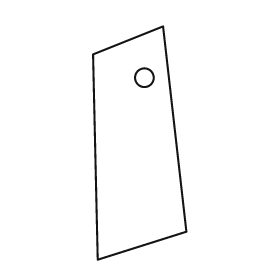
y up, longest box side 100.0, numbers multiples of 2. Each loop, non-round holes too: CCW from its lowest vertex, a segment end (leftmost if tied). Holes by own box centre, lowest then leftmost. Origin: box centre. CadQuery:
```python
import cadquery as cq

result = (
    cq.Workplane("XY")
    .moveTo(-18.0, -50.0)
    .lineTo(20.0, -38.0)
    .lineTo(10.0, 50.0)
    .lineTo(-20.0, 38.0)
    .close()
    .moveTo(2.0, 28.0)
    .circle(4.0)
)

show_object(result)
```